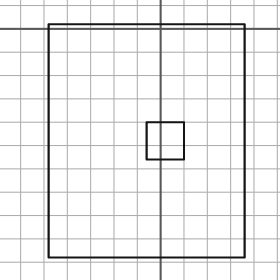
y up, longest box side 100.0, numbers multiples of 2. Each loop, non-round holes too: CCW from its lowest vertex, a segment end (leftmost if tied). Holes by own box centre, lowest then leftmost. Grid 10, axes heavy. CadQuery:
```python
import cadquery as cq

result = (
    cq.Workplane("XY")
    .moveTo(-48.0, -98.0)
    .lineTo(36.0, -98.0)
    .lineTo(36.0, 2.0)
    .lineTo(-48.0, 2.0)
    .close()
    .moveTo(-6.0, -56.0)
    .lineTo(10.0, -56.0)
    .lineTo(10.0, -40.0)
    .lineTo(-6.0, -40.0)
    .close()
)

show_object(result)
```